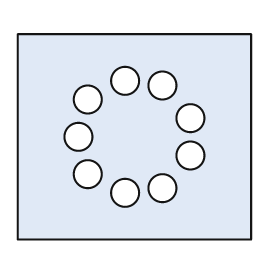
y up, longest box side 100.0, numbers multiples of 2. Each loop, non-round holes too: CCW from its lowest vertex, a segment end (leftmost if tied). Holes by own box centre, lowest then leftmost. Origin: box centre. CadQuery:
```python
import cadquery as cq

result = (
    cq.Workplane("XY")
    .moveTo(-50.0, -44.0)
    .lineTo(50.0, -44.0)
    .lineTo(50.0, 44.0)
    .lineTo(-50.0, 44.0)
    .close()
    .moveTo(-4.0, -24.0)
    .circle(6.0)
    .moveTo(12.0, -22.0)
    .circle(6.0)
    .moveTo(-20.0, -16.0)
    .circle(6.0)
    .moveTo(24.0, -8.0)
    .circle(6.0)
    .moveTo(-24.0, 0.0)
    .circle(6.0)
    .moveTo(24.0, 8.0)
    .circle(6.0)
    .moveTo(-20.0, 16.0)
    .circle(6.0)
    .moveTo(12.0, 22.0)
    .circle(6.0)
    .moveTo(-4.0, 24.0)
    .circle(6.0)
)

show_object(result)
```